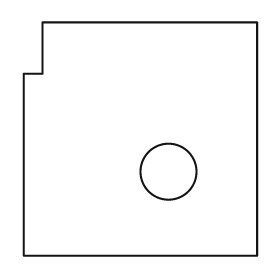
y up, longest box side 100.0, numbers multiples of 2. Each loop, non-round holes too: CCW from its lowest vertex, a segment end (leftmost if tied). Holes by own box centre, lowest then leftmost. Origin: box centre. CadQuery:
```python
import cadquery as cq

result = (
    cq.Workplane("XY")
    .moveTo(-50.0, -50.0)
    .lineTo(50.0, -50.0)
    .lineTo(50.0, 50.0)
    .lineTo(-42.0, 50.0)
    .lineTo(-42.0, 28.0)
    .lineTo(-50.0, 28.0)
    .close()
    .moveTo(12.0, -14.0)
    .circle(12.0)
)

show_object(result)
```